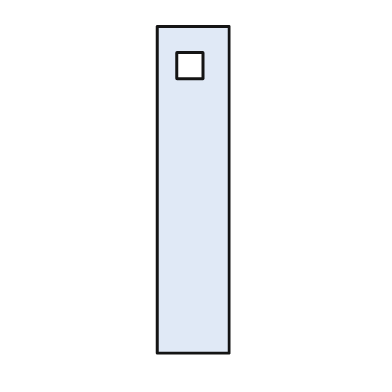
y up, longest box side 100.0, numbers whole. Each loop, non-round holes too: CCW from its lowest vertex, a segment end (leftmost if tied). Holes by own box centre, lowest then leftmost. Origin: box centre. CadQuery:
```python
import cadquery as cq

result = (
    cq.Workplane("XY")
    .moveTo(-11.0, -50.0)
    .lineTo(11.0, -50.0)
    .lineTo(11.0, 50.0)
    .lineTo(-11.0, 50.0)
    .close()
    .moveTo(-5.0, 34.0)
    .lineTo(3.0, 34.0)
    .lineTo(3.0, 42.0)
    .lineTo(-5.0, 42.0)
    .close()
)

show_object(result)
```